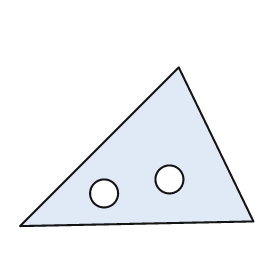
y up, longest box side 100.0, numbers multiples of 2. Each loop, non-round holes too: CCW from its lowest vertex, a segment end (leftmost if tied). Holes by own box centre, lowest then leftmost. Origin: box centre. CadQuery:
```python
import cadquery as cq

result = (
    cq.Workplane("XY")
    .moveTo(-50.0, -34.0)
    .lineTo(50.0, -32.0)
    .lineTo(18.0, 34.0)
    .close()
    .moveTo(-14.0, -20.0)
    .circle(6.0)
    .moveTo(14.0, -14.0)
    .circle(6.0)
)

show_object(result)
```